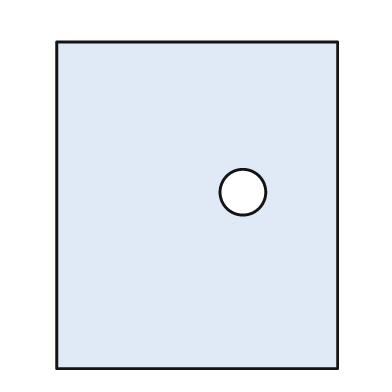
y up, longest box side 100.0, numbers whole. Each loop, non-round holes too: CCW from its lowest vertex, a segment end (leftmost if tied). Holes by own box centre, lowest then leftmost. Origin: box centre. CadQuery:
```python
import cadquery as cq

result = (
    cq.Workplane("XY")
    .moveTo(-43.0, -50.0)
    .lineTo(43.0, -50.0)
    .lineTo(43.0, 50.0)
    .lineTo(-43.0, 50.0)
    .close()
    .moveTo(14.0, 4.0)
    .circle(7.0)
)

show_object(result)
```